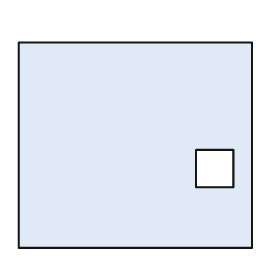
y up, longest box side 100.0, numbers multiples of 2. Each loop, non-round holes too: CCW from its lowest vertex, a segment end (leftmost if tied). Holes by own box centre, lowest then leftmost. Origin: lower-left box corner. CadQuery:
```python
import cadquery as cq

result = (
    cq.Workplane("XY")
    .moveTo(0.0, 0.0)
    .lineTo(100.0, 0.0)
    .lineTo(100.0, 88.0)
    .lineTo(0.0, 88.0)
    .close()
    .moveTo(76.0, 26.0)
    .lineTo(92.0, 26.0)
    .lineTo(92.0, 42.0)
    .lineTo(76.0, 42.0)
    .close()
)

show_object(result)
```